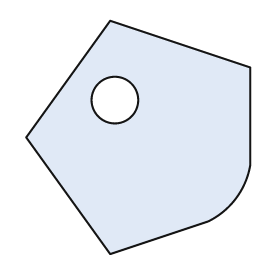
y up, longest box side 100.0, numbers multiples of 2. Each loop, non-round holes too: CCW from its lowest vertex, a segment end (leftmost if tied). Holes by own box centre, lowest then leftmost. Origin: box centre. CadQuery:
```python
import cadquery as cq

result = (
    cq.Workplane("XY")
    .moveTo(-12.0, -50.0)
    .lineTo(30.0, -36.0)
    .threePointArc((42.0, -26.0), (48.0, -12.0))
    .lineTo(48.0, 30.0)
    .lineTo(-12.0, 50.0)
    .lineTo(-48.0, 0.0)
    .close()
    .moveTo(-10.0, 16.0)
    .circle(10.0)
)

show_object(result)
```